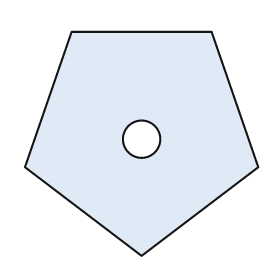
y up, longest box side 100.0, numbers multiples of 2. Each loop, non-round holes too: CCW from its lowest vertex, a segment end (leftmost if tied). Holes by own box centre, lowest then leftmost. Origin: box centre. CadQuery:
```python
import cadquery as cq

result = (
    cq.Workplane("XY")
    .moveTo(0.0, -48.0)
    .lineTo(50.0, -10.0)
    .lineTo(30.0, 48.0)
    .lineTo(-30.0, 48.0)
    .lineTo(-50.0, -10.0)
    .close()
    .moveTo(0.0, 2.0)
    .circle(8.0)
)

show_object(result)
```